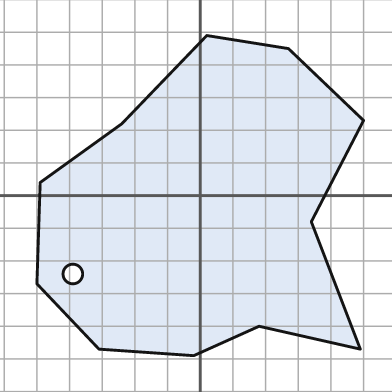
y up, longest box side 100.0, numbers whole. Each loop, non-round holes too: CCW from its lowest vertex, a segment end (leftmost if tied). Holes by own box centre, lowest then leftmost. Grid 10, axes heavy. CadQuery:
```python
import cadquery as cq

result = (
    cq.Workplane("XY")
    .moveTo(-2.0, -49.0)
    .lineTo(18.0, -40.0)
    .lineTo(49.0, -47.0)
    .lineTo(34.0, -8.0)
    .lineTo(50.0, 23.0)
    .lineTo(27.0, 45.0)
    .lineTo(2.0, 49.0)
    .lineTo(-24.0, 22.0)
    .lineTo(-49.0, 4.0)
    .lineTo(-50.0, -27.0)
    .lineTo(-31.0, -47.0)
    .close()
    .moveTo(-39.0, -24.0)
    .circle(3.0)
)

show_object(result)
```